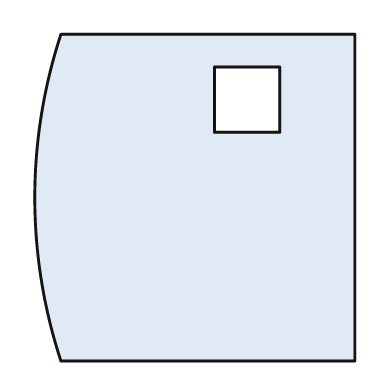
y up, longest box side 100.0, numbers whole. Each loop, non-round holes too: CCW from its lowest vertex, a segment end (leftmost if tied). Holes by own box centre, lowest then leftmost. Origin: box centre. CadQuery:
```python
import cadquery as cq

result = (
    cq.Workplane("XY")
    .moveTo(-41.0, -50.0)
    .lineTo(49.0, -50.0)
    .lineTo(49.0, 50.0)
    .lineTo(-41.0, 50.0)
    .threePointArc((-49.0, 0.0), (-41.0, -50.0))
    .close()
    .moveTo(6.0, 20.0)
    .lineTo(26.0, 20.0)
    .lineTo(26.0, 40.0)
    .lineTo(6.0, 40.0)
    .close()
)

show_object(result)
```